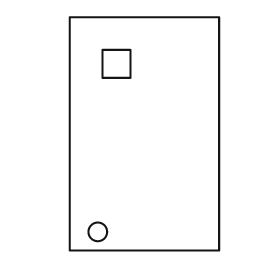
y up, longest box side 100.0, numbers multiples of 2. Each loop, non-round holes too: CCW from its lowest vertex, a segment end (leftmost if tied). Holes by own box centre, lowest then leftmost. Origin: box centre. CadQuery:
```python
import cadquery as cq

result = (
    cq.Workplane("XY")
    .moveTo(-32.0, -50.0)
    .lineTo(32.0, -50.0)
    .lineTo(32.0, 50.0)
    .lineTo(-32.0, 50.0)
    .close()
    .moveTo(-20.0, -42.0)
    .circle(4.0)
    .moveTo(-18.0, 24.0)
    .lineTo(-6.0, 24.0)
    .lineTo(-6.0, 36.0)
    .lineTo(-18.0, 36.0)
    .close()
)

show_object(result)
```